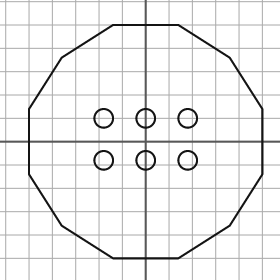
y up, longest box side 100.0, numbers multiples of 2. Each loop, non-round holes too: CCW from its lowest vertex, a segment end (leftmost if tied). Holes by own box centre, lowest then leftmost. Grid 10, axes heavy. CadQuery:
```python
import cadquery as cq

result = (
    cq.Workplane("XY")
    .moveTo(-14.0, -50.0)
    .lineTo(14.0, -50.0)
    .lineTo(36.0, -36.0)
    .lineTo(50.0, -14.0)
    .lineTo(50.0, 14.0)
    .lineTo(36.0, 36.0)
    .lineTo(14.0, 50.0)
    .lineTo(-14.0, 50.0)
    .lineTo(-36.0, 36.0)
    .lineTo(-50.0, 14.0)
    .lineTo(-50.0, -14.0)
    .lineTo(-36.0, -36.0)
    .close()
    .moveTo(-18.0, -8.0)
    .circle(4.0)
    .moveTo(0.0, -8.0)
    .circle(4.0)
    .moveTo(18.0, -8.0)
    .circle(4.0)
    .moveTo(-18.0, 10.0)
    .circle(4.0)
    .moveTo(0.0, 10.0)
    .circle(4.0)
    .moveTo(18.0, 10.0)
    .circle(4.0)
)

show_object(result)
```